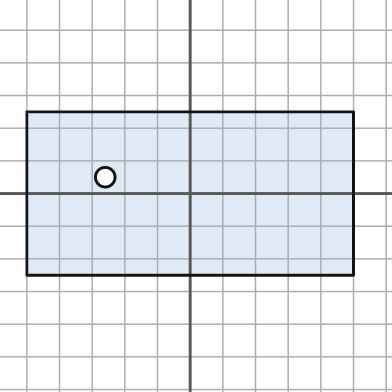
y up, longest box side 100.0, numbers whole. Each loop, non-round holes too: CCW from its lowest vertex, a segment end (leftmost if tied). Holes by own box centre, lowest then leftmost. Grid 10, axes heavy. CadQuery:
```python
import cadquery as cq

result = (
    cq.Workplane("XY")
    .moveTo(-50.0, -25.0)
    .lineTo(50.0, -25.0)
    .lineTo(50.0, 25.0)
    .lineTo(-50.0, 25.0)
    .close()
    .moveTo(-26.0, 5.0)
    .circle(3.0)
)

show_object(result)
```